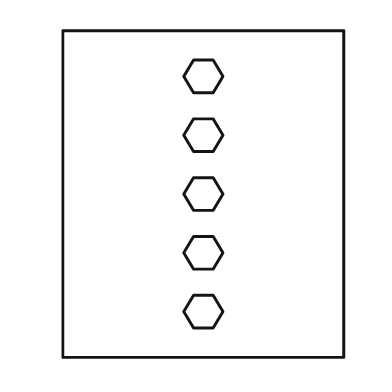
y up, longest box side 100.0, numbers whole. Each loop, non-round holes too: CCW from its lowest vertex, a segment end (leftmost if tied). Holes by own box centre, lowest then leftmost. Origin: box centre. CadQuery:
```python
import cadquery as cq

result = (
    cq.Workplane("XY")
    .moveTo(-43.0, -50.0)
    .lineTo(43.0, -50.0)
    .lineTo(43.0, 50.0)
    .lineTo(-43.0, 50.0)
    .close()
    .moveTo(-3.0, -41.0)
    .lineTo(3.0, -41.0)
    .lineTo(6.0, -36.0)
    .lineTo(3.0, -31.0)
    .lineTo(-3.0, -31.0)
    .lineTo(-6.0, -36.0)
    .close()
    .moveTo(-3.0, -23.0)
    .lineTo(3.0, -23.0)
    .lineTo(6.0, -18.0)
    .lineTo(3.0, -13.0)
    .lineTo(-3.0, -13.0)
    .lineTo(-6.0, -18.0)
    .close()
    .moveTo(-3.0, -5.0)
    .lineTo(3.0, -5.0)
    .lineTo(6.0, 0.0)
    .lineTo(3.0, 5.0)
    .lineTo(-3.0, 5.0)
    .lineTo(-6.0, 0.0)
    .close()
    .moveTo(-3.0, 13.0)
    .lineTo(3.0, 13.0)
    .lineTo(6.0, 18.0)
    .lineTo(3.0, 23.0)
    .lineTo(-3.0, 23.0)
    .lineTo(-6.0, 18.0)
    .close()
    .moveTo(-3.0, 31.0)
    .lineTo(3.0, 31.0)
    .lineTo(6.0, 36.0)
    .lineTo(3.0, 41.0)
    .lineTo(-3.0, 41.0)
    .lineTo(-6.0, 36.0)
    .close()
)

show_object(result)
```